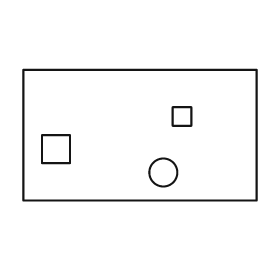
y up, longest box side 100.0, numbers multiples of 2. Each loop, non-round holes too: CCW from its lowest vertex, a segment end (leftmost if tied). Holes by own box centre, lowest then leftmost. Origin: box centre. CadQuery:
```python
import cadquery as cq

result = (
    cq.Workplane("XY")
    .moveTo(-50.0, -28.0)
    .lineTo(50.0, -28.0)
    .lineTo(50.0, 28.0)
    .lineTo(-50.0, 28.0)
    .close()
    .moveTo(10.0, -16.0)
    .circle(6.0)
    .moveTo(-42.0, -12.0)
    .lineTo(-30.0, -12.0)
    .lineTo(-30.0, 0.0)
    .lineTo(-42.0, 0.0)
    .close()
    .moveTo(14.0, 4.0)
    .lineTo(22.0, 4.0)
    .lineTo(22.0, 12.0)
    .lineTo(14.0, 12.0)
    .close()
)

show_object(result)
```